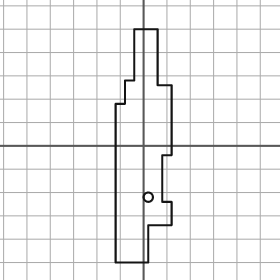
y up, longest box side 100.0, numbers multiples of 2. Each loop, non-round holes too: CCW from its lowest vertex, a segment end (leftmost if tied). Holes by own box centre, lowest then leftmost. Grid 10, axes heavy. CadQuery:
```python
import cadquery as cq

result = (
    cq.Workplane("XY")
    .moveTo(-12.0, -50.0)
    .lineTo(2.0, -50.0)
    .lineTo(2.0, -34.0)
    .lineTo(12.0, -34.0)
    .lineTo(12.0, -24.0)
    .lineTo(8.0, -24.0)
    .lineTo(8.0, -4.0)
    .lineTo(12.0, -4.0)
    .lineTo(12.0, 26.0)
    .lineTo(6.0, 26.0)
    .lineTo(6.0, 50.0)
    .lineTo(-4.0, 50.0)
    .lineTo(-4.0, 28.0)
    .lineTo(-8.0, 28.0)
    .lineTo(-8.0, 18.0)
    .lineTo(-12.0, 18.0)
    .close()
    .moveTo(2.0, -22.0)
    .circle(2.0)
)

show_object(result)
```